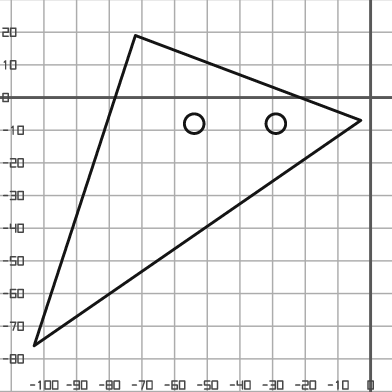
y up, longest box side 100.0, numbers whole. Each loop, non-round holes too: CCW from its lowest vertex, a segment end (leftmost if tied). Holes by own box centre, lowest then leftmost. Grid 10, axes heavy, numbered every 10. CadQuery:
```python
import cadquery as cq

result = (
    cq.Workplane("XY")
    .moveTo(-103.0, -76.0)
    .lineTo(-3.0, -7.0)
    .lineTo(-72.0, 19.0)
    .close()
    .moveTo(-54.0, -8.0)
    .circle(3.0)
    .moveTo(-29.0, -8.0)
    .circle(3.0)
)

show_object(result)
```